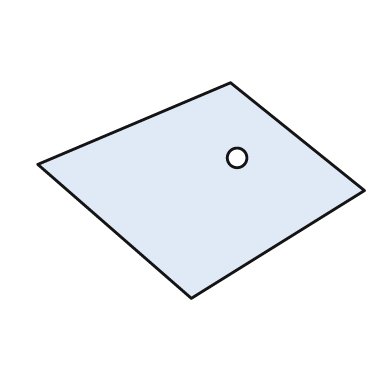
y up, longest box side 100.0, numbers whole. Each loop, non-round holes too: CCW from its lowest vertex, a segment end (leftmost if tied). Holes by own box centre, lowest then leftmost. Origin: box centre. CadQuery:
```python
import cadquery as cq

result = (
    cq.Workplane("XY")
    .moveTo(-3.0, -33.0)
    .lineTo(50.0, 0.0)
    .lineTo(9.0, 33.0)
    .lineTo(-50.0, 8.0)
    .close()
    .moveTo(11.0, 10.0)
    .circle(3.0)
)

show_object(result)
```